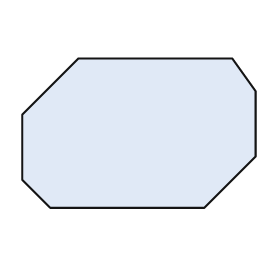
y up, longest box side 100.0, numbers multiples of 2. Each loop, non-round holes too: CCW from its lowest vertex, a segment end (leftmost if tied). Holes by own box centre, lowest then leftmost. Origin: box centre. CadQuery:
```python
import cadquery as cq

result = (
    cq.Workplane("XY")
    .moveTo(-38.0, -32.0)
    .lineTo(28.0, -32.0)
    .lineTo(50.0, -10.0)
    .lineTo(50.0, 18.0)
    .lineTo(40.0, 32.0)
    .lineTo(-26.0, 32.0)
    .lineTo(-50.0, 8.0)
    .lineTo(-50.0, -20.0)
    .close()
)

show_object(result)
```